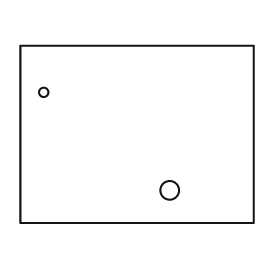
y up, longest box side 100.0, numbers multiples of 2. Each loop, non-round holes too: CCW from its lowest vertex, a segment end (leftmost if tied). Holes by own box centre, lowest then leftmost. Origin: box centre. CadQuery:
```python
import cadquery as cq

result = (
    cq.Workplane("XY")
    .moveTo(-50.0, -38.0)
    .lineTo(50.0, -38.0)
    .lineTo(50.0, 38.0)
    .lineTo(-50.0, 38.0)
    .close()
    .moveTo(14.0, -24.0)
    .circle(4.0)
    .moveTo(-40.0, 18.0)
    .circle(2.0)
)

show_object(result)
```